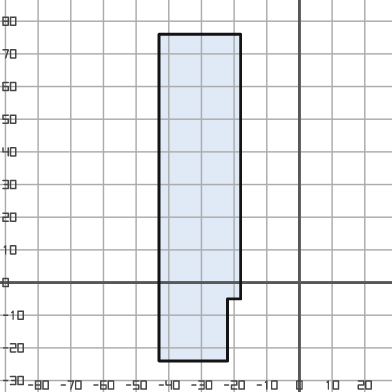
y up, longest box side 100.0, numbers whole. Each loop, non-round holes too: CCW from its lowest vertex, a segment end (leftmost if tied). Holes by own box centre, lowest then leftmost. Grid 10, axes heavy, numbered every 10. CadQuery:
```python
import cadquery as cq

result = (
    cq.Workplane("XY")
    .moveTo(-43.0, -24.0)
    .lineTo(-22.0, -24.0)
    .lineTo(-22.0, -5.0)
    .lineTo(-18.0, -5.0)
    .lineTo(-18.0, 76.0)
    .lineTo(-43.0, 76.0)
    .close()
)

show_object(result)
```